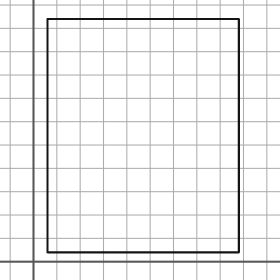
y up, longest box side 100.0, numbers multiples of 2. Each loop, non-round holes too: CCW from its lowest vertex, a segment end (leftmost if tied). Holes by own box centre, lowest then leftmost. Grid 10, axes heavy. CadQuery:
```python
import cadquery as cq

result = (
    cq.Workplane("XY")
    .moveTo(6.0, 4.0)
    .lineTo(88.0, 4.0)
    .lineTo(88.0, 104.0)
    .lineTo(6.0, 104.0)
    .close()
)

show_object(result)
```